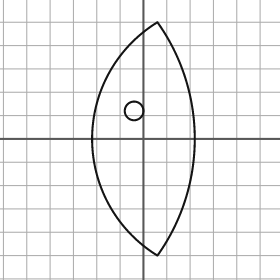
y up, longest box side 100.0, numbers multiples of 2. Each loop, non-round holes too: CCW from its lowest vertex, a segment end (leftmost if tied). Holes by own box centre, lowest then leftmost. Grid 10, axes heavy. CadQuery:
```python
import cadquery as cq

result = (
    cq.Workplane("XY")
    .moveTo(6.0, -50.0)
    .threePointArc((22.0, 0.0), (6.0, 50.0))
    .threePointArc((-22.0, 0.0), (6.0, -50.0))
    .close()
    .moveTo(-4.0, 12.0)
    .circle(4.0)
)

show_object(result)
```